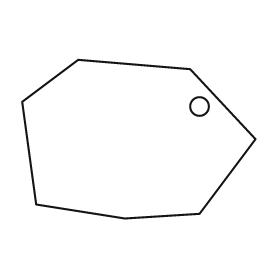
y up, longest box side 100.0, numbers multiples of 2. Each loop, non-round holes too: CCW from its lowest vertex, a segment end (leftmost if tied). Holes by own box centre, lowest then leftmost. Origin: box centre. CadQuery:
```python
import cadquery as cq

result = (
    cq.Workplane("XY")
    .moveTo(-6.0, -34.0)
    .lineTo(26.0, -32.0)
    .lineTo(50.0, 0.0)
    .lineTo(22.0, 30.0)
    .lineTo(-26.0, 34.0)
    .lineTo(-50.0, 16.0)
    .lineTo(-44.0, -28.0)
    .close()
    .moveTo(26.0, 14.0)
    .circle(4.0)
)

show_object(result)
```